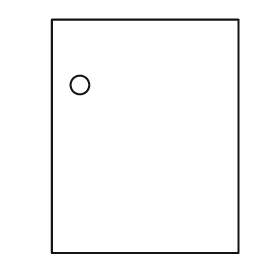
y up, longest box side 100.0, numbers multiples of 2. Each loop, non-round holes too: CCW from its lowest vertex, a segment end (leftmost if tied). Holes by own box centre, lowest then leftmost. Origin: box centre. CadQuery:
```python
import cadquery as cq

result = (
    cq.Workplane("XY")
    .moveTo(-40.0, -50.0)
    .lineTo(40.0, -50.0)
    .lineTo(40.0, 50.0)
    .lineTo(-40.0, 50.0)
    .close()
    .moveTo(-28.0, 22.0)
    .circle(4.0)
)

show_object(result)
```